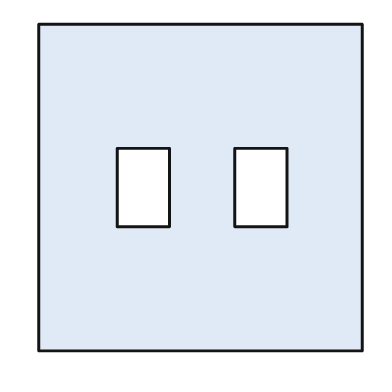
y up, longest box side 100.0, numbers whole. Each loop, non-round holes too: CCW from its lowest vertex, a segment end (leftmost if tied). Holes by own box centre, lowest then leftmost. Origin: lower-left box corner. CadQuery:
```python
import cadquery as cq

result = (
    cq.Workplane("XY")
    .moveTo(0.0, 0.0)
    .lineTo(99.0, 0.0)
    .lineTo(99.0, 100.0)
    .lineTo(0.0, 100.0)
    .close()
    .moveTo(24.0, 38.0)
    .lineTo(40.0, 38.0)
    .lineTo(40.0, 62.0)
    .lineTo(24.0, 62.0)
    .close()
    .moveTo(60.0, 38.0)
    .lineTo(76.0, 38.0)
    .lineTo(76.0, 62.0)
    .lineTo(60.0, 62.0)
    .close()
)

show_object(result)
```